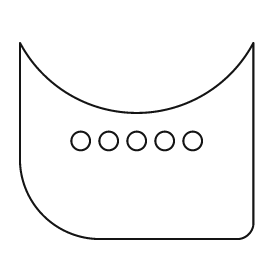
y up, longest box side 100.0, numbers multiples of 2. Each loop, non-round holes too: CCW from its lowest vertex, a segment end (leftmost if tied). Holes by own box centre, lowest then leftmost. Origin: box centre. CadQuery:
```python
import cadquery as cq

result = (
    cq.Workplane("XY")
    .moveTo(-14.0, -42.0)
    .lineTo(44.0, -42.0)
    .threePointArc((48.0, -40.0), (50.0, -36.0))
    .lineTo(50.0, 42.0)
    .threePointArc((0.0, 12.0), (-50.0, 42.0))
    .lineTo(-50.0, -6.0)
    .threePointArc((-40.0, -32.0), (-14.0, -42.0))
    .close()
    .moveTo(-24.0, 0.0)
    .circle(4.0)
    .moveTo(-12.0, 0.0)
    .circle(4.0)
    .moveTo(0.0, 0.0)
    .circle(4.0)
    .moveTo(12.0, 0.0)
    .circle(4.0)
    .moveTo(24.0, 0.0)
    .circle(4.0)
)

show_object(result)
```